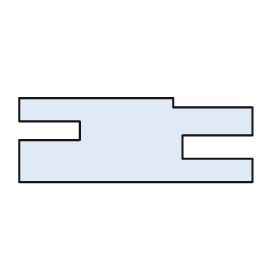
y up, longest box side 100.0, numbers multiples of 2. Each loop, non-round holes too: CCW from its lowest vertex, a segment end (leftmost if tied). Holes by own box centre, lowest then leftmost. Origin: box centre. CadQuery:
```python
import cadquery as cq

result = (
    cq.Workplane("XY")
    .moveTo(-50.0, -18.0)
    .lineTo(50.0, -18.0)
    .lineTo(50.0, -8.0)
    .lineTo(20.0, -8.0)
    .lineTo(20.0, 2.0)
    .lineTo(50.0, 2.0)
    .lineTo(50.0, 14.0)
    .lineTo(16.0, 14.0)
    .lineTo(16.0, 18.0)
    .lineTo(-50.0, 18.0)
    .lineTo(-50.0, 8.0)
    .lineTo(-24.0, 8.0)
    .lineTo(-24.0, 0.0)
    .lineTo(-50.0, 0.0)
    .close()
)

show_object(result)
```